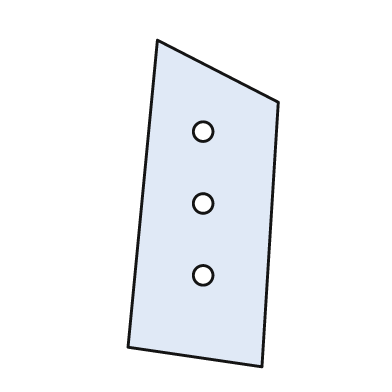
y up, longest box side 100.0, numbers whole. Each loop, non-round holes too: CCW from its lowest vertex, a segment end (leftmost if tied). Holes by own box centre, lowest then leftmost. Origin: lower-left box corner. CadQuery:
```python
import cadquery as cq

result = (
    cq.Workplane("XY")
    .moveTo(41.0, 0.0)
    .lineTo(46.0, 81.0)
    .lineTo(9.0, 100.0)
    .lineTo(0.0, 6.0)
    .close()
    .moveTo(23.0, 28.0)
    .circle(3.0)
    .moveTo(23.0, 50.0)
    .circle(3.0)
    .moveTo(23.0, 72.0)
    .circle(3.0)
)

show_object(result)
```